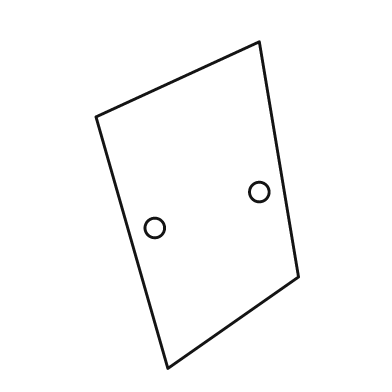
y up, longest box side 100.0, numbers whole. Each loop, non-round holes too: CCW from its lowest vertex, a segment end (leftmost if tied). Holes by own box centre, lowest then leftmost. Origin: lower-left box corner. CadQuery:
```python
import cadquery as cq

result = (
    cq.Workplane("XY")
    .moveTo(22.0, 0.0)
    .lineTo(62.0, 28.0)
    .lineTo(50.0, 100.0)
    .lineTo(0.0, 77.0)
    .close()
    .moveTo(18.0, 43.0)
    .circle(3.0)
    .moveTo(50.0, 54.0)
    .circle(3.0)
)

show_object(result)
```